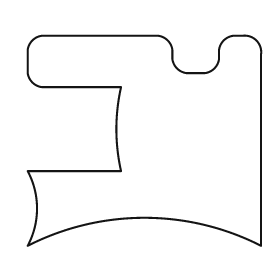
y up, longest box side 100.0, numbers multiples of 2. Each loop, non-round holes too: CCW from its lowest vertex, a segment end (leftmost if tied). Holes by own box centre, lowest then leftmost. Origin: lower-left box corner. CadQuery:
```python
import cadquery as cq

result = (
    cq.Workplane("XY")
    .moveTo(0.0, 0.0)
    .threePointArc((50.0, 12.0), (100.0, 0.0))
    .lineTo(100.0, 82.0)
    .threePointArc((98.0, 88.0), (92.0, 90.0))
    .lineTo(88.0, 90.0)
    .threePointArc((84.0, 88.0), (82.0, 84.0))
    .lineTo(82.0, 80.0)
    .threePointArc((80.0, 76.0), (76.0, 74.0))
    .lineTo(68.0, 74.0)
    .threePointArc((64.0, 76.0), (62.0, 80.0))
    .lineTo(62.0, 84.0)
    .threePointArc((60.0, 88.0), (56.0, 90.0))
    .lineTo(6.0, 90.0)
    .threePointArc((2.0, 88.0), (0.0, 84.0))
    .lineTo(0.0, 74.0)
    .threePointArc((2.0, 70.0), (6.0, 68.0))
    .lineTo(40.0, 68.0)
    .threePointArc((38.0, 50.0), (40.0, 32.0))
    .lineTo(0.0, 32.0)
    .threePointArc((4.0, 16.0), (0.0, 0.0))
    .close()
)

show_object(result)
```